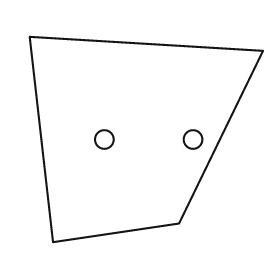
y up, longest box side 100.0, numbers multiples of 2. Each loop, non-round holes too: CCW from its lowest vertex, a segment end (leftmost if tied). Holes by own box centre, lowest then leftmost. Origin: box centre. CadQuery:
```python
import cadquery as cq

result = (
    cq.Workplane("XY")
    .moveTo(-40.0, -44.0)
    .lineTo(14.0, -36.0)
    .lineTo(50.0, 38.0)
    .lineTo(-50.0, 44.0)
    .close()
    .moveTo(-18.0, 0.0)
    .circle(4.0)
    .moveTo(20.0, 0.0)
    .circle(4.0)
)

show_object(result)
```